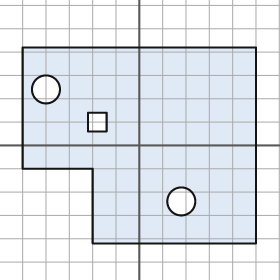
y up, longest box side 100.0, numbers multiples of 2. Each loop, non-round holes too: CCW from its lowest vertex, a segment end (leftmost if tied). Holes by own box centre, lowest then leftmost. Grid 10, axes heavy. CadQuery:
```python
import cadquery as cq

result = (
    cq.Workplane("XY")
    .moveTo(-20.0, -42.0)
    .lineTo(50.0, -42.0)
    .lineTo(50.0, 42.0)
    .lineTo(-50.0, 42.0)
    .lineTo(-50.0, -10.0)
    .lineTo(-20.0, -10.0)
    .close()
    .moveTo(18.0, -24.0)
    .circle(6.0)
    .moveTo(-22.0, 6.0)
    .lineTo(-14.0, 6.0)
    .lineTo(-14.0, 14.0)
    .lineTo(-22.0, 14.0)
    .close()
    .moveTo(-40.0, 24.0)
    .circle(6.0)
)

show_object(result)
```